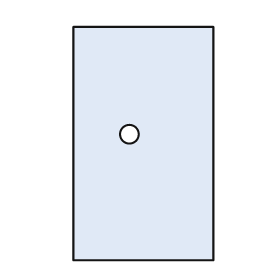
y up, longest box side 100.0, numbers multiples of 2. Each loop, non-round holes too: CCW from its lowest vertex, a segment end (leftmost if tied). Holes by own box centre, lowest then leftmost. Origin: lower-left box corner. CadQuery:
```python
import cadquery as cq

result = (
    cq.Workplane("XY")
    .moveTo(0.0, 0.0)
    .lineTo(60.0, 0.0)
    .lineTo(60.0, 100.0)
    .lineTo(0.0, 100.0)
    .close()
    .moveTo(24.0, 54.0)
    .circle(4.0)
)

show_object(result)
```